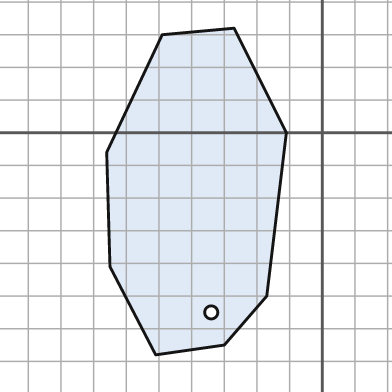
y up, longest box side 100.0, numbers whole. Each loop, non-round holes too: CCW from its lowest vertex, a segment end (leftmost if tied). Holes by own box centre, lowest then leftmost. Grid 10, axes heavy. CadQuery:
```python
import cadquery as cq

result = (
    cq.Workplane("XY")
    .moveTo(-51.0, -68.0)
    .lineTo(-30.0, -65.0)
    .lineTo(-17.0, -50.0)
    .lineTo(-11.0, 0.0)
    .lineTo(-27.0, 32.0)
    .lineTo(-49.0, 30.0)
    .lineTo(-66.0, -6.0)
    .lineTo(-65.0, -41.0)
    .close()
    .moveTo(-34.0, -55.0)
    .circle(2.0)
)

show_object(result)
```